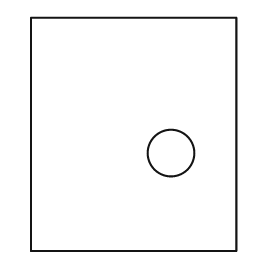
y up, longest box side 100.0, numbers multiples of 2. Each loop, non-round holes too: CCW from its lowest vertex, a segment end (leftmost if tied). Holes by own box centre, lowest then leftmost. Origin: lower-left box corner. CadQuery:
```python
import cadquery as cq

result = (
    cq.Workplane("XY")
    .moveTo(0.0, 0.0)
    .lineTo(88.0, 0.0)
    .lineTo(88.0, 100.0)
    .lineTo(0.0, 100.0)
    .close()
    .moveTo(60.0, 42.0)
    .circle(10.0)
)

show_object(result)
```